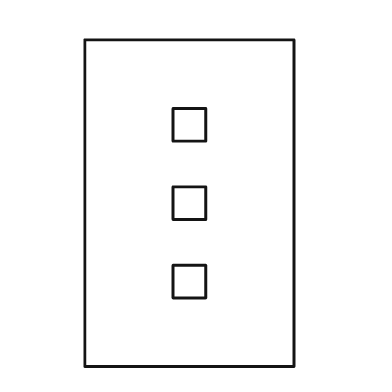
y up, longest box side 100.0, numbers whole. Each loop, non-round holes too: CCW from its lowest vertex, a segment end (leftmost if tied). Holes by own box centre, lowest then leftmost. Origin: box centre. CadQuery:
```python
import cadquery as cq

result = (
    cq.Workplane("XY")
    .moveTo(-32.0, -50.0)
    .lineTo(32.0, -50.0)
    .lineTo(32.0, 50.0)
    .lineTo(-32.0, 50.0)
    .close()
    .moveTo(-5.0, -29.0)
    .lineTo(5.0, -29.0)
    .lineTo(5.0, -19.0)
    .lineTo(-5.0, -19.0)
    .close()
    .moveTo(-5.0, -5.0)
    .lineTo(5.0, -5.0)
    .lineTo(5.0, 5.0)
    .lineTo(-5.0, 5.0)
    .close()
    .moveTo(-5.0, 19.0)
    .lineTo(5.0, 19.0)
    .lineTo(5.0, 29.0)
    .lineTo(-5.0, 29.0)
    .close()
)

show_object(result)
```